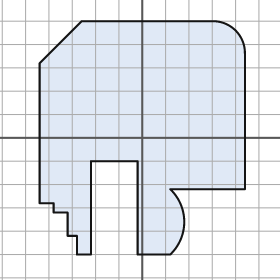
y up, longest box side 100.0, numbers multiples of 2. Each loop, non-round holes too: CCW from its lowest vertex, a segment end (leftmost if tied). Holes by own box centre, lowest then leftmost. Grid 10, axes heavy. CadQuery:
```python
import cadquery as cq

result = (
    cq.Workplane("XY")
    .moveTo(-28.0, -50.0)
    .lineTo(-22.0, -50.0)
    .lineTo(-22.0, -10.0)
    .lineTo(-2.0, -10.0)
    .lineTo(-2.0, -50.0)
    .lineTo(12.0, -50.0)
    .threePointArc((18.0, -36.0), (12.0, -22.0))
    .lineTo(44.0, -22.0)
    .lineTo(44.0, 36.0)
    .threePointArc((40.0, 46.0), (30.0, 50.0))
    .lineTo(-26.0, 50.0)
    .lineTo(-44.0, 32.0)
    .lineTo(-44.0, -28.0)
    .lineTo(-38.0, -28.0)
    .lineTo(-38.0, -32.0)
    .lineTo(-32.0, -32.0)
    .lineTo(-32.0, -42.0)
    .lineTo(-28.0, -42.0)
    .close()
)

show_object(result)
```